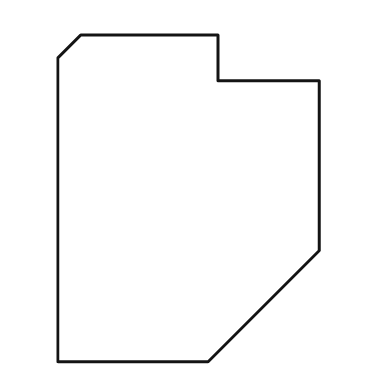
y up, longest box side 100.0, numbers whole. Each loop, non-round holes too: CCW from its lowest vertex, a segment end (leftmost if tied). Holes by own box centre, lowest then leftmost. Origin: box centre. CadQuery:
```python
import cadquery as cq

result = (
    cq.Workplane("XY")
    .moveTo(-40.0, -50.0)
    .lineTo(6.0, -50.0)
    .lineTo(40.0, -16.0)
    .lineTo(40.0, 36.0)
    .lineTo(9.0, 36.0)
    .lineTo(9.0, 50.0)
    .lineTo(-33.0, 50.0)
    .lineTo(-40.0, 43.0)
    .close()
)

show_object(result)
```